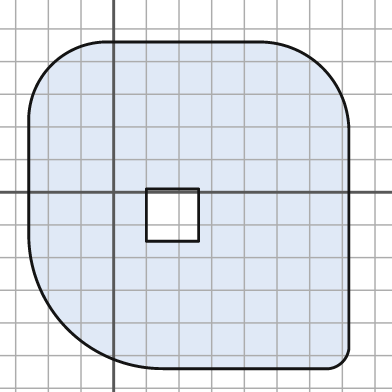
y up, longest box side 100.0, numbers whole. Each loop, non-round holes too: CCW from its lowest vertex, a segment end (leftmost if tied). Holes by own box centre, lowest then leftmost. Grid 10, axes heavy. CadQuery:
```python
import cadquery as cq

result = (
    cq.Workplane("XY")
    .moveTo(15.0, -54.0)
    .lineTo(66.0, -54.0)
    .threePointArc((70.0, -52.0), (72.0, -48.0))
    .lineTo(72.0, 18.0)
    .threePointArc((64.0, 38.0), (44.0, 46.0))
    .lineTo(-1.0, 46.0)
    .threePointArc((-19.0, 39.0), (-26.0, 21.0))
    .lineTo(-26.0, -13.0)
    .threePointArc((-14.0, -42.0), (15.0, -54.0))
    .close()
    .moveTo(10.0, -15.0)
    .lineTo(26.0, -15.0)
    .lineTo(26.0, 1.0)
    .lineTo(10.0, 1.0)
    .close()
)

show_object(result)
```